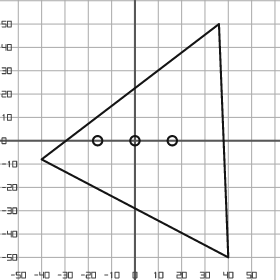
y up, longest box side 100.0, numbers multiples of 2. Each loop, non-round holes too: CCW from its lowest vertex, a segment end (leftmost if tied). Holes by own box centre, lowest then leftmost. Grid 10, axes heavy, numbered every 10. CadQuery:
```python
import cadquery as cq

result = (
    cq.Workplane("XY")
    .moveTo(40.0, -50.0)
    .lineTo(36.0, 50.0)
    .lineTo(-40.0, -8.0)
    .close()
    .moveTo(-16.0, 0.0)
    .circle(2.0)
    .moveTo(0.0, 0.0)
    .circle(2.0)
    .moveTo(16.0, 0.0)
    .circle(2.0)
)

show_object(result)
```